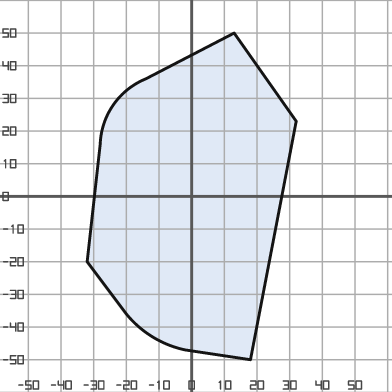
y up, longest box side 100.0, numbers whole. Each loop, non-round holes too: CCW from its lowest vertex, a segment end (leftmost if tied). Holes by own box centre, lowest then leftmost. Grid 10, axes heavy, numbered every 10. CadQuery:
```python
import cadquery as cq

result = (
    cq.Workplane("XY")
    .moveTo(18.0, -50.0)
    .lineTo(32.0, 23.0)
    .lineTo(13.0, 50.0)
    .lineTo(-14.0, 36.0)
    .threePointArc((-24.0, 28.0), (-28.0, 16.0))
    .lineTo(-32.0, -20.0)
    .lineTo(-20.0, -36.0)
    .threePointArc((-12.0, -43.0), (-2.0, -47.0))
    .close()
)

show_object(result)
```